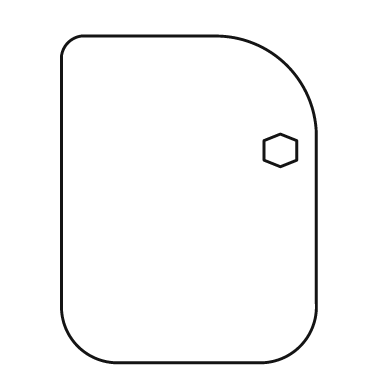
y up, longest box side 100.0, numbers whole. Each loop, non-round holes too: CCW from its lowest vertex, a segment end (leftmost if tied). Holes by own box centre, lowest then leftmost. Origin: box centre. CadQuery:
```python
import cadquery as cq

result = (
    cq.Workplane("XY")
    .moveTo(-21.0, -50.0)
    .lineTo(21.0, -50.0)
    .threePointArc((34.0, -45.0), (39.0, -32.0))
    .lineTo(39.0, 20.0)
    .threePointArc((30.0, 41.0), (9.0, 50.0))
    .lineTo(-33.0, 50.0)
    .threePointArc((-37.0, 48.0), (-39.0, 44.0))
    .lineTo(-39.0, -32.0)
    .threePointArc((-34.0, -45.0), (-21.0, -50.0))
    .close()
    .moveTo(28.0, 10.0)
    .lineTo(33.0, 12.0)
    .lineTo(33.0, 18.0)
    .lineTo(28.0, 20.0)
    .lineTo(23.0, 18.0)
    .lineTo(23.0, 12.0)
    .close()
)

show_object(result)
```